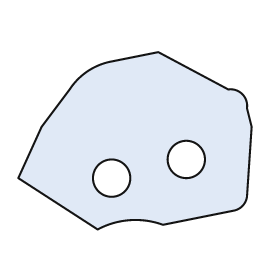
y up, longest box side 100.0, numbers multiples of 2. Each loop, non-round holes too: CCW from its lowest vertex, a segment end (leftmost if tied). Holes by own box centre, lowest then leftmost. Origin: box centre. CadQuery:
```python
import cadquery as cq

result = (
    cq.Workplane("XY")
    .moveTo(-16.0, -38.0)
    .threePointArc((-2.0, -34.0), (12.0, -36.0))
    .lineTo(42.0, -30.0)
    .threePointArc((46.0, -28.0), (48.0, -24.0))
    .lineTo(50.0, 6.0)
    .lineTo(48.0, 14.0)
    .threePointArc((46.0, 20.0), (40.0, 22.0))
    .lineTo(10.0, 38.0)
    .lineTo(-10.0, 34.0)
    .threePointArc((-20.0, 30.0), (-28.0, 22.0))
    .lineTo(-40.0, 6.0)
    .lineTo(-50.0, -16.0)
    .close()
    .moveTo(-10.0, -16.0)
    .circle(8.0)
    .moveTo(22.0, -8.0)
    .circle(8.0)
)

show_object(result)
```